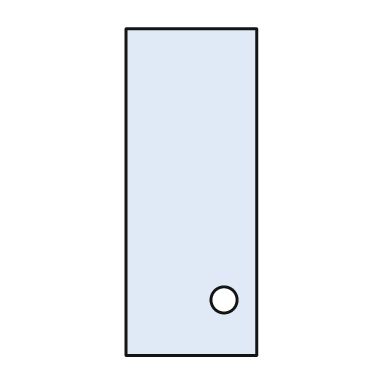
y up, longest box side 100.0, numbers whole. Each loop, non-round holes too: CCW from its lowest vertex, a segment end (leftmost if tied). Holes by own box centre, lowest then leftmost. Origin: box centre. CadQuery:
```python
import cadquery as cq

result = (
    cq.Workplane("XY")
    .moveTo(-20.0, -50.0)
    .lineTo(20.0, -50.0)
    .lineTo(20.0, 50.0)
    .lineTo(-20.0, 50.0)
    .close()
    .moveTo(10.0, -33.0)
    .circle(4.0)
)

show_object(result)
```